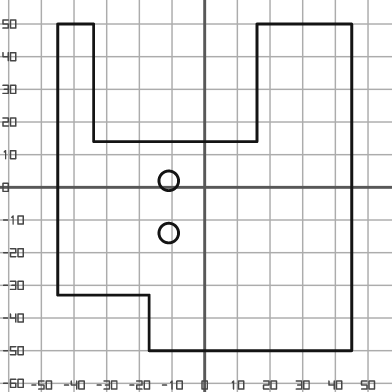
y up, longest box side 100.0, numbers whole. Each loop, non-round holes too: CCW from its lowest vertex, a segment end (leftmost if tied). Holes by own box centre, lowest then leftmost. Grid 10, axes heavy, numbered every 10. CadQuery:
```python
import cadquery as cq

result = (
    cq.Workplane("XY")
    .moveTo(-17.0, -50.0)
    .lineTo(45.0, -50.0)
    .lineTo(45.0, 50.0)
    .lineTo(16.0, 50.0)
    .lineTo(16.0, 14.0)
    .lineTo(-34.0, 14.0)
    .lineTo(-34.0, 50.0)
    .lineTo(-45.0, 50.0)
    .lineTo(-45.0, -33.0)
    .lineTo(-17.0, -33.0)
    .close()
    .moveTo(-11.0, -14.0)
    .circle(3.0)
    .moveTo(-11.0, 2.0)
    .circle(3.0)
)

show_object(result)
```